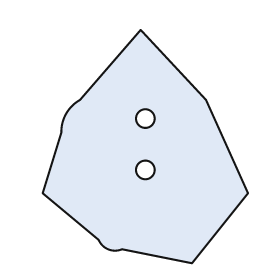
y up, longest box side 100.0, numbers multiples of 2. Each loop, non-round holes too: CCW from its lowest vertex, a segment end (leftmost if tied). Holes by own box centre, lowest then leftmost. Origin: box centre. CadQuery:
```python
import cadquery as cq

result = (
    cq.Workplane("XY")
    .moveTo(20.0, -50.0)
    .lineTo(44.0, -20.0)
    .lineTo(26.0, 20.0)
    .lineTo(-2.0, 50.0)
    .lineTo(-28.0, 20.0)
    .threePointArc((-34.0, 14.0), (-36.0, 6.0))
    .lineTo(-44.0, -20.0)
    .lineTo(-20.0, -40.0)
    .threePointArc((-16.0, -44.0), (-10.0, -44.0))
    .close()
    .moveTo(0.0, -10.0)
    .circle(4.0)
    .moveTo(0.0, 12.0)
    .circle(4.0)
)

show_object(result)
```